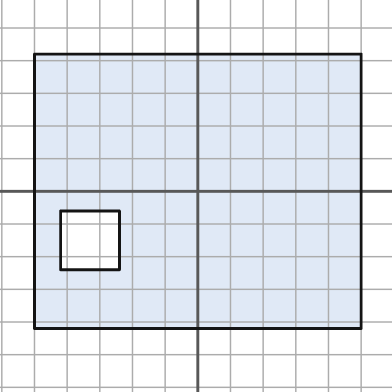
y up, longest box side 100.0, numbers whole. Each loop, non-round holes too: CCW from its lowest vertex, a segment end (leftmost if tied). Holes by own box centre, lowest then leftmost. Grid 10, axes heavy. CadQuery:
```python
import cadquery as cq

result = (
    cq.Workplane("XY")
    .moveTo(-50.0, -42.0)
    .lineTo(50.0, -42.0)
    .lineTo(50.0, 42.0)
    .lineTo(-50.0, 42.0)
    .close()
    .moveTo(-42.0, -24.0)
    .lineTo(-24.0, -24.0)
    .lineTo(-24.0, -6.0)
    .lineTo(-42.0, -6.0)
    .close()
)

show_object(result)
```